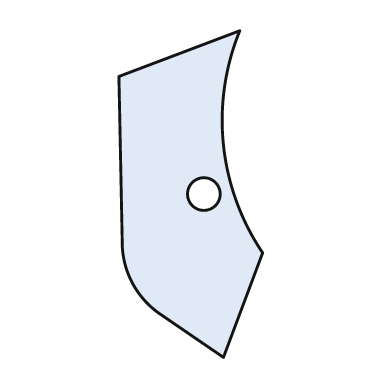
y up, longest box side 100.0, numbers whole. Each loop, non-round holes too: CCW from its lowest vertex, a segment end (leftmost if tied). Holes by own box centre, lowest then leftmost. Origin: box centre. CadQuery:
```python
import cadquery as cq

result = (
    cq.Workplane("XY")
    .moveTo(10.0, -50.0)
    .lineTo(22.0, -18.0)
    .threePointArc((10.0, 15.0), (15.0, 50.0))
    .lineTo(-22.0, 36.0)
    .lineTo(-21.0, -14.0)
    .threePointArc((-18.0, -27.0), (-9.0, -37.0))
    .close()
    .moveTo(4.0, 0.0)
    .circle(5.0)
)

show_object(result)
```